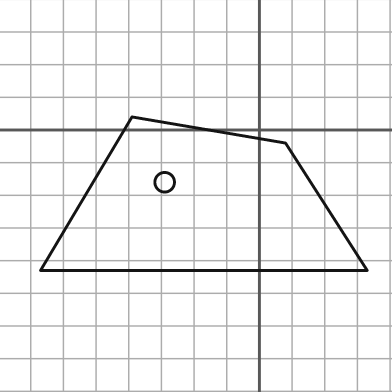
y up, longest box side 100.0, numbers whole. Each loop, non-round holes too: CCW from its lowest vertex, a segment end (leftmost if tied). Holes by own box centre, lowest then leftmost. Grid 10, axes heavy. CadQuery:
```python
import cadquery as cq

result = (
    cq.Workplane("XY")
    .moveTo(-67.0, -43.0)
    .lineTo(33.0, -43.0)
    .lineTo(8.0, -4.0)
    .lineTo(-39.0, 4.0)
    .close()
    .moveTo(-29.0, -16.0)
    .circle(3.0)
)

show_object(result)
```